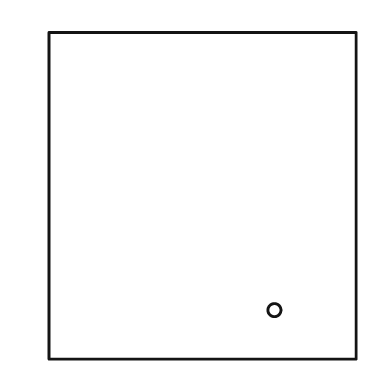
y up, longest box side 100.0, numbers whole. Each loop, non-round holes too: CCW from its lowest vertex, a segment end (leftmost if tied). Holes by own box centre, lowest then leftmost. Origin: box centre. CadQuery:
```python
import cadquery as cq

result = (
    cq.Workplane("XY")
    .moveTo(-47.0, -50.0)
    .lineTo(47.0, -50.0)
    .lineTo(47.0, 50.0)
    .lineTo(-47.0, 50.0)
    .close()
    .moveTo(22.0, -35.0)
    .circle(2.0)
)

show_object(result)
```